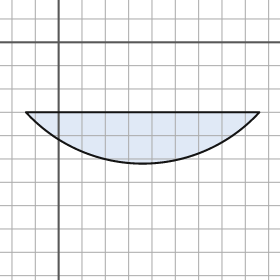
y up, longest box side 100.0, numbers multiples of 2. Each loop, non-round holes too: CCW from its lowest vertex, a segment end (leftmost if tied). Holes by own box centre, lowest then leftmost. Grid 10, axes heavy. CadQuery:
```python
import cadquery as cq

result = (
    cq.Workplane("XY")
    .moveTo(-14.0, -30.0)
    .threePointArc((36.0, -52.0), (86.0, -30.0))
    .close()
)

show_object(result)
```